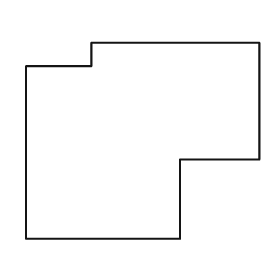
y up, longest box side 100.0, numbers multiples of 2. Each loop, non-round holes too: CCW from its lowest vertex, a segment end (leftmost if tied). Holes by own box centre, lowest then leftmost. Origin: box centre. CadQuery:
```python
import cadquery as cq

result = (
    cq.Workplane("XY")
    .moveTo(-50.0, -42.0)
    .lineTo(16.0, -42.0)
    .lineTo(16.0, -8.0)
    .lineTo(50.0, -8.0)
    .lineTo(50.0, 42.0)
    .lineTo(-22.0, 42.0)
    .lineTo(-22.0, 32.0)
    .lineTo(-50.0, 32.0)
    .close()
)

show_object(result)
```